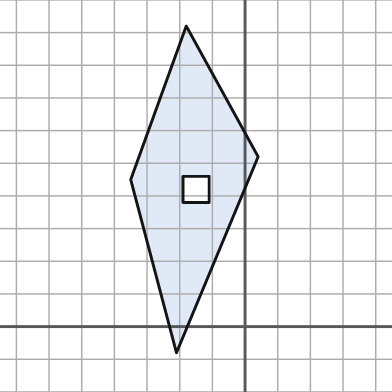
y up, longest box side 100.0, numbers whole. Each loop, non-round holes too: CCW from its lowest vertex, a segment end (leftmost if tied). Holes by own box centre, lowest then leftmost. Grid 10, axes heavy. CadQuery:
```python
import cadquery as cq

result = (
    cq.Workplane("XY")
    .moveTo(-21.0, -8.0)
    .lineTo(4.0, 52.0)
    .lineTo(-18.0, 92.0)
    .lineTo(-35.0, 45.0)
    .close()
    .moveTo(-19.0, 38.0)
    .lineTo(-11.0, 38.0)
    .lineTo(-11.0, 46.0)
    .lineTo(-19.0, 46.0)
    .close()
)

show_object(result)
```